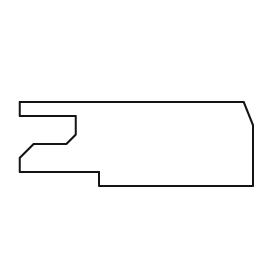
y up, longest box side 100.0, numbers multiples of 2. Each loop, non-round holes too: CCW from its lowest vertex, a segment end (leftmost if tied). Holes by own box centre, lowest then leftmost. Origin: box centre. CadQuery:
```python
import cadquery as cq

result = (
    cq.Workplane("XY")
    .moveTo(-16.0, -18.0)
    .lineTo(50.0, -18.0)
    .lineTo(50.0, 8.0)
    .lineTo(46.0, 18.0)
    .lineTo(-50.0, 18.0)
    .lineTo(-50.0, 12.0)
    .lineTo(-26.0, 12.0)
    .lineTo(-26.0, 4.0)
    .lineTo(-30.0, 0.0)
    .lineTo(-44.0, 0.0)
    .lineTo(-50.0, -6.0)
    .lineTo(-50.0, -12.0)
    .lineTo(-16.0, -12.0)
    .close()
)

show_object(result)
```